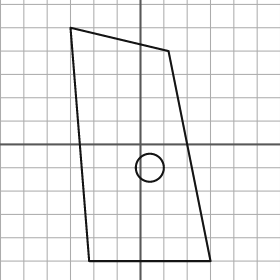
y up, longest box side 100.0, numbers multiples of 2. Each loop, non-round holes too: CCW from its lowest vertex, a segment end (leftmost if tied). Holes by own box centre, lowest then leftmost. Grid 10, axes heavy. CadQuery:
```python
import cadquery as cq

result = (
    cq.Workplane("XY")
    .moveTo(-22.0, -50.0)
    .lineTo(30.0, -50.0)
    .lineTo(12.0, 40.0)
    .lineTo(-30.0, 50.0)
    .close()
    .moveTo(4.0, -10.0)
    .circle(6.0)
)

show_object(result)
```